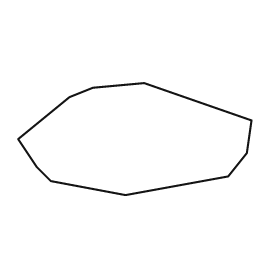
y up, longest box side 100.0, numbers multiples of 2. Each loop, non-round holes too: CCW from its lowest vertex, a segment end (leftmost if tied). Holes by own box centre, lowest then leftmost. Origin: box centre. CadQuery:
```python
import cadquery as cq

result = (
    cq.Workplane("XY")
    .moveTo(-4.0, -24.0)
    .lineTo(40.0, -16.0)
    .lineTo(48.0, -6.0)
    .lineTo(50.0, 8.0)
    .lineTo(4.0, 24.0)
    .lineTo(-18.0, 22.0)
    .lineTo(-28.0, 18.0)
    .lineTo(-50.0, 0.0)
    .lineTo(-42.0, -12.0)
    .lineTo(-36.0, -18.0)
    .close()
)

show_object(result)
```